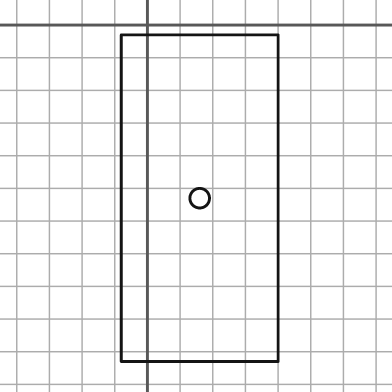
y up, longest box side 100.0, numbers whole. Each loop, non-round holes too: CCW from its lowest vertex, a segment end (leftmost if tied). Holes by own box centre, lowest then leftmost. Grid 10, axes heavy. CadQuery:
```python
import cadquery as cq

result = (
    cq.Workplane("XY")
    .moveTo(-8.0, -103.0)
    .lineTo(40.0, -103.0)
    .lineTo(40.0, -3.0)
    .lineTo(-8.0, -3.0)
    .close()
    .moveTo(16.0, -53.0)
    .circle(3.0)
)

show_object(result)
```